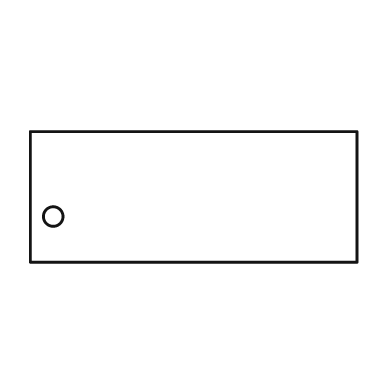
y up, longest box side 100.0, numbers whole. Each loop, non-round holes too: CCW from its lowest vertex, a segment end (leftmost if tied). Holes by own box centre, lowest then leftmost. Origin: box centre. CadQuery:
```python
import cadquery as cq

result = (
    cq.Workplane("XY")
    .moveTo(-50.0, -20.0)
    .lineTo(50.0, -20.0)
    .lineTo(50.0, 20.0)
    .lineTo(-50.0, 20.0)
    .close()
    .moveTo(-43.0, -6.0)
    .circle(3.0)
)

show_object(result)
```